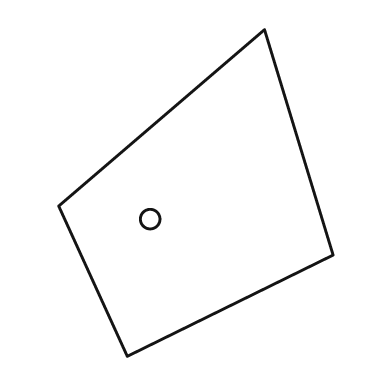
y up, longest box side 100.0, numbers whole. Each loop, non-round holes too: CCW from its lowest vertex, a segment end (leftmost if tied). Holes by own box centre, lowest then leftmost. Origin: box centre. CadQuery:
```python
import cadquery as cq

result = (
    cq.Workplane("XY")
    .moveTo(-21.0, -50.0)
    .lineTo(42.0, -19.0)
    .lineTo(21.0, 50.0)
    .lineTo(-42.0, -4.0)
    .close()
    .moveTo(-14.0, -8.0)
    .circle(3.0)
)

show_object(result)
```